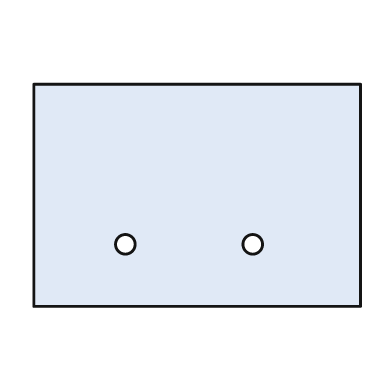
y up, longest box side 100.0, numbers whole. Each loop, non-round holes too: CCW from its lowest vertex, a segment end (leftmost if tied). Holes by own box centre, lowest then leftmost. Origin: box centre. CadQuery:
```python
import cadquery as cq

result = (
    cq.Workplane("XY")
    .moveTo(-50.0, -34.0)
    .lineTo(50.0, -34.0)
    .lineTo(50.0, 34.0)
    .lineTo(-50.0, 34.0)
    .close()
    .moveTo(-22.0, -15.0)
    .circle(3.0)
    .moveTo(17.0, -15.0)
    .circle(3.0)
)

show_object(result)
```